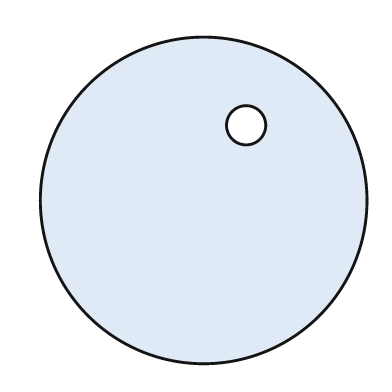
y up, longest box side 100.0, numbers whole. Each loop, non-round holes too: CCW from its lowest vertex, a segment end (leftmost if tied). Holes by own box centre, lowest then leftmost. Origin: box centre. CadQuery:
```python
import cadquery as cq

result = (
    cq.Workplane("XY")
    .moveTo(0.0, 0.0)
    .circle(50.0)
    .moveTo(13.0, 23.0)
    .circle(6.0)
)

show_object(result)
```